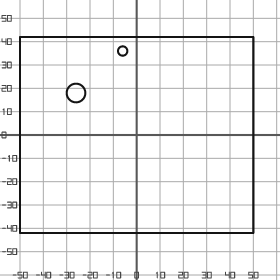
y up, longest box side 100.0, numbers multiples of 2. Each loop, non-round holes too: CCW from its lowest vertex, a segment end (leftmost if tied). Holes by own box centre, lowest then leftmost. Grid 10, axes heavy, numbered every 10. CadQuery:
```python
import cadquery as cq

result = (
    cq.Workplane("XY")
    .moveTo(-50.0, -42.0)
    .lineTo(50.0, -42.0)
    .lineTo(50.0, 42.0)
    .lineTo(-50.0, 42.0)
    .close()
    .moveTo(-26.0, 18.0)
    .circle(4.0)
    .moveTo(-6.0, 36.0)
    .circle(2.0)
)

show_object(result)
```